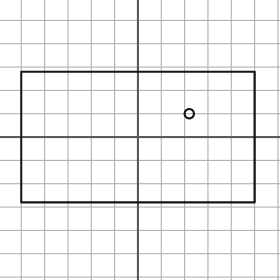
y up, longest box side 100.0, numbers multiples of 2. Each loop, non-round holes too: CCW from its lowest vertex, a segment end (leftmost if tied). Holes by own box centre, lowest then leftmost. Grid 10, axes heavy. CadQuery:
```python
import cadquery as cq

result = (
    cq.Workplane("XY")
    .moveTo(-50.0, -28.0)
    .lineTo(50.0, -28.0)
    .lineTo(50.0, 28.0)
    .lineTo(-50.0, 28.0)
    .close()
    .moveTo(22.0, 10.0)
    .circle(2.0)
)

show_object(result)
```